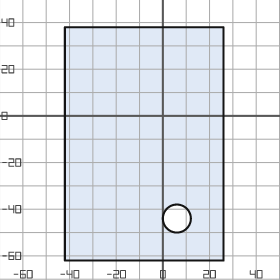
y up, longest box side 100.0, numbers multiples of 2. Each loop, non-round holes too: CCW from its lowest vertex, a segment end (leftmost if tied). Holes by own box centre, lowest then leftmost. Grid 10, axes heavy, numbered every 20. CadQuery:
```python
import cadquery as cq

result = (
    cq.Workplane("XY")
    .moveTo(-42.0, -62.0)
    .lineTo(26.0, -62.0)
    .lineTo(26.0, 38.0)
    .lineTo(-42.0, 38.0)
    .close()
    .moveTo(6.0, -44.0)
    .circle(6.0)
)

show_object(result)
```